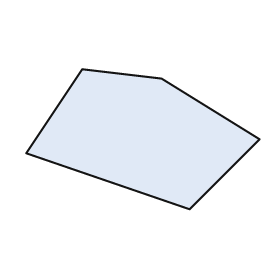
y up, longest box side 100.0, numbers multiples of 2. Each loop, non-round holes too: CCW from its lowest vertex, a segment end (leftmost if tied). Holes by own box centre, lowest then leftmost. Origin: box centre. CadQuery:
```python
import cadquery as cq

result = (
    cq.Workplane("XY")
    .moveTo(20.0, -30.0)
    .lineTo(50.0, 0.0)
    .lineTo(8.0, 26.0)
    .lineTo(-26.0, 30.0)
    .lineTo(-50.0, -6.0)
    .close()
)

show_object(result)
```